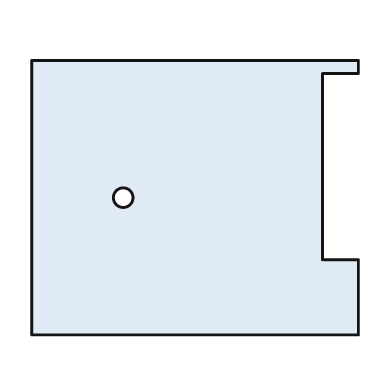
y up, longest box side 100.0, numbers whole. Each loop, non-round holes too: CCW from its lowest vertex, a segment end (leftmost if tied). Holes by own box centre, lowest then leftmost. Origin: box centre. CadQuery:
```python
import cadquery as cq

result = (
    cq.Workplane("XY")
    .moveTo(-50.0, -42.0)
    .lineTo(50.0, -42.0)
    .lineTo(50.0, -19.0)
    .lineTo(39.0, -19.0)
    .lineTo(39.0, 38.0)
    .lineTo(50.0, 38.0)
    .lineTo(50.0, 42.0)
    .lineTo(-50.0, 42.0)
    .close()
    .moveTo(-22.0, 0.0)
    .circle(3.0)
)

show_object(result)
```